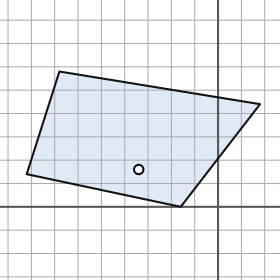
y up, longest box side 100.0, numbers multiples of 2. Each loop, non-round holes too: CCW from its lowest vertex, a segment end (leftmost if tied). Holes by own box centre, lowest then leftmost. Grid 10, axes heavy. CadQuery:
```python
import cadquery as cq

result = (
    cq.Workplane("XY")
    .moveTo(-16.0, 0.0)
    .lineTo(18.0, 44.0)
    .lineTo(-68.0, 58.0)
    .lineTo(-82.0, 14.0)
    .close()
    .moveTo(-34.0, 16.0)
    .circle(2.0)
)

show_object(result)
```